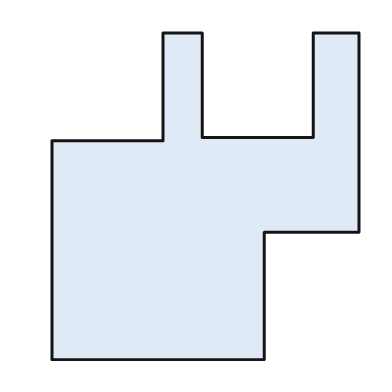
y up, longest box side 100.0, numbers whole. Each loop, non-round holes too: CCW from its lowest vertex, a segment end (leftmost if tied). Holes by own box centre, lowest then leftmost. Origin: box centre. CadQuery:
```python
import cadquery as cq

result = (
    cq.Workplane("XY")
    .moveTo(-47.0, -50.0)
    .lineTo(18.0, -50.0)
    .lineTo(18.0, -11.0)
    .lineTo(47.0, -11.0)
    .lineTo(47.0, 50.0)
    .lineTo(33.0, 50.0)
    .lineTo(33.0, 18.0)
    .lineTo(-1.0, 18.0)
    .lineTo(-1.0, 50.0)
    .lineTo(-13.0, 50.0)
    .lineTo(-13.0, 17.0)
    .lineTo(-47.0, 17.0)
    .close()
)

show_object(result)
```